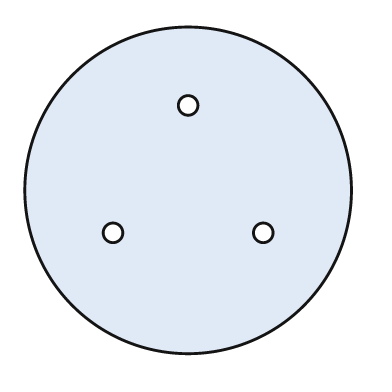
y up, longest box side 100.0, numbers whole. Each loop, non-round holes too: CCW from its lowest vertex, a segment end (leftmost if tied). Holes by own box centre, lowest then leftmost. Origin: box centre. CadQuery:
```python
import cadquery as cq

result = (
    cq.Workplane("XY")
    .moveTo(0.0, 0.0)
    .circle(50.0)
    .moveTo(-23.0, -13.0)
    .circle(3.0)
    .moveTo(23.0, -13.0)
    .circle(3.0)
    .moveTo(0.0, 26.0)
    .circle(3.0)
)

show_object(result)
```